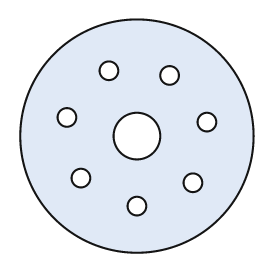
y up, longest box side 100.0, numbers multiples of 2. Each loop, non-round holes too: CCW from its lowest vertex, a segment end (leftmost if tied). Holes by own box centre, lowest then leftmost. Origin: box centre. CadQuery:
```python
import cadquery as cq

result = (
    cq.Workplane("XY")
    .moveTo(0.0, 0.0)
    .circle(50.0)
    .moveTo(0.0, -30.0)
    .circle(4.0)
    .moveTo(24.0, -20.0)
    .circle(4.0)
    .moveTo(-24.0, -18.0)
    .circle(4.0)
    .moveTo(0.0, 0.0)
    .circle(10.0)
    .moveTo(30.0, 6.0)
    .circle(4.0)
    .moveTo(-30.0, 8.0)
    .circle(4.0)
    .moveTo(14.0, 26.0)
    .circle(4.0)
    .moveTo(-12.0, 28.0)
    .circle(4.0)
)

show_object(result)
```